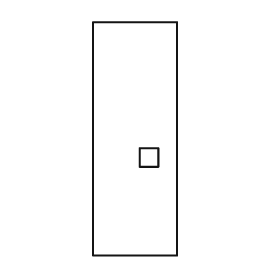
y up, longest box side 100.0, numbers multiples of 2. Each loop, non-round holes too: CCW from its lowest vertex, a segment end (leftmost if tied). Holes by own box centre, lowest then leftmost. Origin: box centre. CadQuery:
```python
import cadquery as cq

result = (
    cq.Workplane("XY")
    .moveTo(-18.0, -50.0)
    .lineTo(18.0, -50.0)
    .lineTo(18.0, 50.0)
    .lineTo(-18.0, 50.0)
    .close()
    .moveTo(2.0, -12.0)
    .lineTo(10.0, -12.0)
    .lineTo(10.0, -4.0)
    .lineTo(2.0, -4.0)
    .close()
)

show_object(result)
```